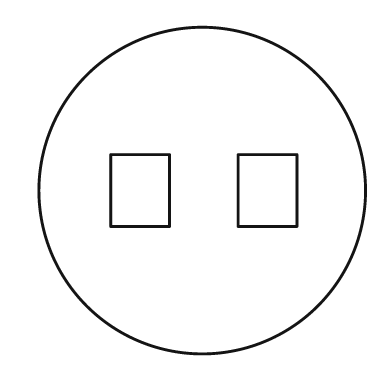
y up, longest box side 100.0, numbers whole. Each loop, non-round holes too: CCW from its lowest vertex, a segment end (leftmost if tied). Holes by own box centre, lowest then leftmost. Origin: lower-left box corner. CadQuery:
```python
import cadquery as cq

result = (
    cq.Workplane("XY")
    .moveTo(50.0, 50.0)
    .circle(50.0)
    .moveTo(22.0, 39.0)
    .lineTo(40.0, 39.0)
    .lineTo(40.0, 61.0)
    .lineTo(22.0, 61.0)
    .close()
    .moveTo(61.0, 39.0)
    .lineTo(79.0, 39.0)
    .lineTo(79.0, 61.0)
    .lineTo(61.0, 61.0)
    .close()
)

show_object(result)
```